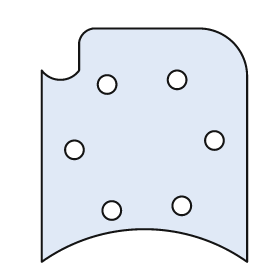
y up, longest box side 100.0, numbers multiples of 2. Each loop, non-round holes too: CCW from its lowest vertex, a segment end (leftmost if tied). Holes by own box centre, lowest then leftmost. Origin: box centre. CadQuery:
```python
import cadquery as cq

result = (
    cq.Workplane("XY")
    .moveTo(-44.0, -50.0)
    .threePointArc((0.0, -36.0), (44.0, -50.0))
    .lineTo(44.0, 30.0)
    .threePointArc((38.0, 44.0), (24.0, 50.0))
    .lineTo(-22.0, 50.0)
    .threePointArc((-26.0, 48.0), (-28.0, 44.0))
    .lineTo(-28.0, 32.0)
    .threePointArc((-36.0, 28.0), (-44.0, 32.0))
    .close()
    .moveTo(-14.0, -28.0)
    .circle(4.0)
    .moveTo(16.0, -26.0)
    .circle(4.0)
    .moveTo(-30.0, -2.0)
    .circle(4.0)
    .moveTo(30.0, 2.0)
    .circle(4.0)
    .moveTo(-16.0, 26.0)
    .circle(4.0)
    .moveTo(14.0, 28.0)
    .circle(4.0)
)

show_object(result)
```